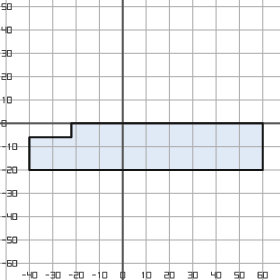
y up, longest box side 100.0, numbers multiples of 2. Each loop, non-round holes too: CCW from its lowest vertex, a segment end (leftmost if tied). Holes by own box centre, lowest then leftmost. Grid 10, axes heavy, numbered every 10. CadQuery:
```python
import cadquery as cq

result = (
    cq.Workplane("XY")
    .moveTo(-40.0, -20.0)
    .lineTo(60.0, -20.0)
    .lineTo(60.0, 0.0)
    .lineTo(-22.0, 0.0)
    .lineTo(-22.0, -6.0)
    .lineTo(-40.0, -6.0)
    .close()
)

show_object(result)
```